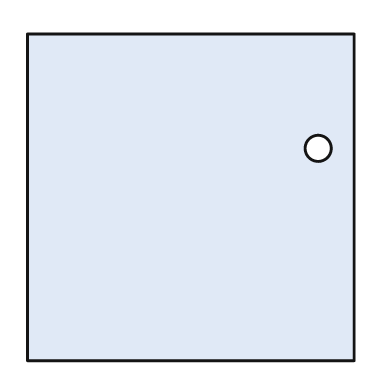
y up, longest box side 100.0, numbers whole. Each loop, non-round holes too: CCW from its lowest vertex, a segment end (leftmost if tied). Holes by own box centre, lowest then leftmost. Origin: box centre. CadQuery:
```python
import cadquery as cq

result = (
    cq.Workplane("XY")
    .moveTo(-50.0, -50.0)
    .lineTo(50.0, -50.0)
    .lineTo(50.0, 50.0)
    .lineTo(-50.0, 50.0)
    .close()
    .moveTo(39.0, 15.0)
    .circle(4.0)
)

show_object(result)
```